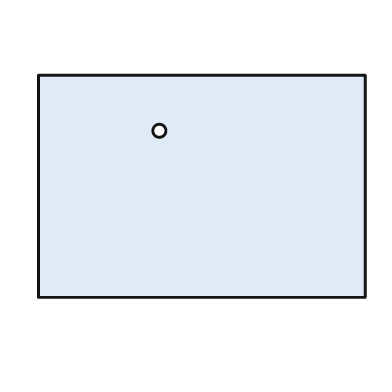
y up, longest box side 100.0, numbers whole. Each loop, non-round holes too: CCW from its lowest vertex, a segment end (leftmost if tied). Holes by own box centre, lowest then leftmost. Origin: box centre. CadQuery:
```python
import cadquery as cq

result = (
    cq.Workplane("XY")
    .moveTo(-50.0, -34.0)
    .lineTo(50.0, -34.0)
    .lineTo(50.0, 34.0)
    .lineTo(-50.0, 34.0)
    .close()
    .moveTo(-13.0, 17.0)
    .circle(2.0)
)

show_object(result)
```